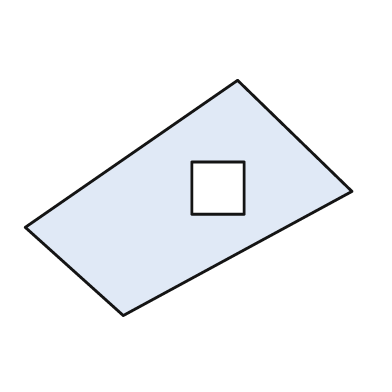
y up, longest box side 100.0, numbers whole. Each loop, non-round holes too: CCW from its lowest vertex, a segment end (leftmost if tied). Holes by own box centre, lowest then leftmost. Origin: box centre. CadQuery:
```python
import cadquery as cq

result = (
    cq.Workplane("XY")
    .moveTo(-20.0, -36.0)
    .lineTo(50.0, 2.0)
    .lineTo(15.0, 36.0)
    .lineTo(-50.0, -9.0)
    .close()
    .moveTo(1.0, -5.0)
    .lineTo(17.0, -5.0)
    .lineTo(17.0, 11.0)
    .lineTo(1.0, 11.0)
    .close()
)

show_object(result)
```